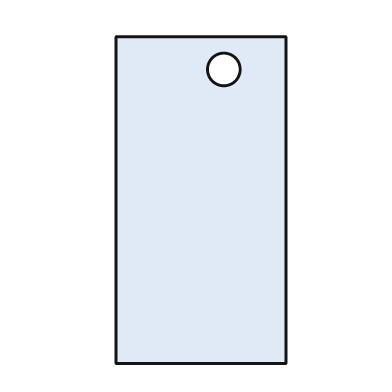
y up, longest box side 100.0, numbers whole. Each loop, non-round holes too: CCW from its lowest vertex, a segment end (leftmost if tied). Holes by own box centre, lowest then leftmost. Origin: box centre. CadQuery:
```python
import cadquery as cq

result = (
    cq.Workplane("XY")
    .moveTo(-26.0, -50.0)
    .lineTo(26.0, -50.0)
    .lineTo(26.0, 50.0)
    .lineTo(-26.0, 50.0)
    .close()
    .moveTo(7.0, 40.0)
    .circle(5.0)
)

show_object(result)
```